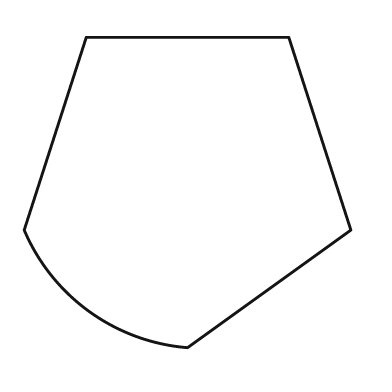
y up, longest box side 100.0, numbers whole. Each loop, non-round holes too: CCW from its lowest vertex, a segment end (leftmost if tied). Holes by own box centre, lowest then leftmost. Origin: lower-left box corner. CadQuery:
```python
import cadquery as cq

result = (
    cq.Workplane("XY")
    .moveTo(50.0, 0.0)
    .lineTo(100.0, 36.0)
    .lineTo(81.0, 95.0)
    .lineTo(19.0, 95.0)
    .lineTo(0.0, 36.0)
    .threePointArc((20.0, 11.0), (50.0, 0.0))
    .close()
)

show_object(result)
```